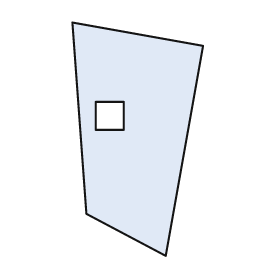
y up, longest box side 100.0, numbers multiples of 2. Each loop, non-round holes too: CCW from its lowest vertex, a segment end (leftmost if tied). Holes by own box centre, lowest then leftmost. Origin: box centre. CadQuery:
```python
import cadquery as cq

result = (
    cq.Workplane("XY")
    .moveTo(12.0, -50.0)
    .lineTo(28.0, 40.0)
    .lineTo(-28.0, 50.0)
    .lineTo(-22.0, -32.0)
    .close()
    .moveTo(-18.0, 4.0)
    .lineTo(-6.0, 4.0)
    .lineTo(-6.0, 16.0)
    .lineTo(-18.0, 16.0)
    .close()
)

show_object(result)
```